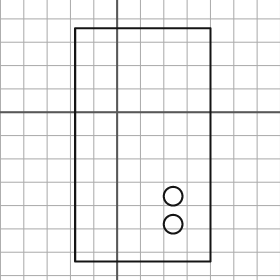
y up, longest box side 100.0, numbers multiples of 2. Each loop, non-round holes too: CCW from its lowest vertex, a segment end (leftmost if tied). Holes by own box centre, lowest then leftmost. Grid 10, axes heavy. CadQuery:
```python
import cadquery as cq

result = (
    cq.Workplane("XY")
    .moveTo(-18.0, -64.0)
    .lineTo(40.0, -64.0)
    .lineTo(40.0, 36.0)
    .lineTo(-18.0, 36.0)
    .close()
    .moveTo(24.0, -48.0)
    .circle(4.0)
    .moveTo(24.0, -36.0)
    .circle(4.0)
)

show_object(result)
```